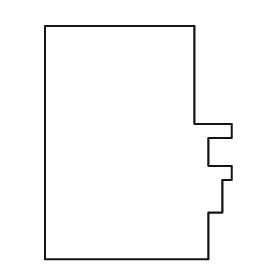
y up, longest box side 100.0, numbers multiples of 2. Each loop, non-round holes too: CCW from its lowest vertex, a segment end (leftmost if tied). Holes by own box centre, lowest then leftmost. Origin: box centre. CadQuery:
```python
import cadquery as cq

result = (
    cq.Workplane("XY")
    .moveTo(-40.0, -50.0)
    .lineTo(30.0, -50.0)
    .lineTo(30.0, -30.0)
    .lineTo(36.0, -30.0)
    .lineTo(36.0, -16.0)
    .lineTo(40.0, -16.0)
    .lineTo(40.0, -10.0)
    .lineTo(30.0, -10.0)
    .lineTo(30.0, 2.0)
    .lineTo(40.0, 2.0)
    .lineTo(40.0, 8.0)
    .lineTo(24.0, 8.0)
    .lineTo(24.0, 50.0)
    .lineTo(-40.0, 50.0)
    .close()
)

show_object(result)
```